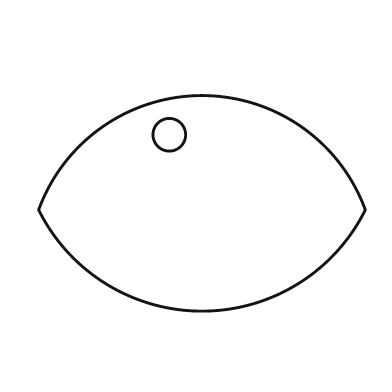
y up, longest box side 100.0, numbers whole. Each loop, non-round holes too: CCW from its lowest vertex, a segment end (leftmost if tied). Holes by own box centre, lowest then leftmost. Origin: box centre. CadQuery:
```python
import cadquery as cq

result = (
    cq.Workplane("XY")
    .moveTo(-50.0, -2.0)
    .threePointArc((0.0, -33.0), (50.0, -2.0))
    .threePointArc((0.0, 33.0), (-50.0, -2.0))
    .close()
    .moveTo(-10.0, 21.0)
    .circle(5.0)
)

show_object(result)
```